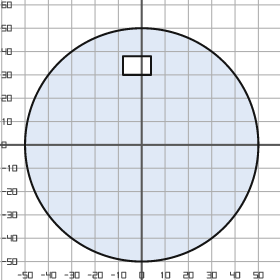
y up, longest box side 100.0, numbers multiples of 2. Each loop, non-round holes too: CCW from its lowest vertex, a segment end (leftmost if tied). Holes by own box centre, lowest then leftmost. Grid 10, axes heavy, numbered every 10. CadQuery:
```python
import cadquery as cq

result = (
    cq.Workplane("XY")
    .moveTo(0.0, 0.0)
    .circle(50.0)
    .moveTo(-8.0, 30.0)
    .lineTo(4.0, 30.0)
    .lineTo(4.0, 38.0)
    .lineTo(-8.0, 38.0)
    .close()
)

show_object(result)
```